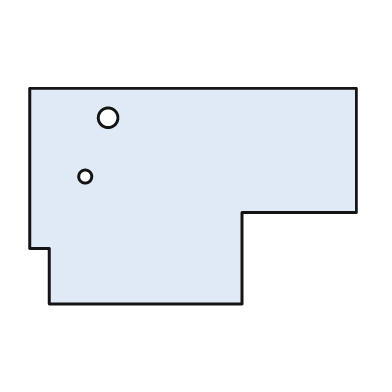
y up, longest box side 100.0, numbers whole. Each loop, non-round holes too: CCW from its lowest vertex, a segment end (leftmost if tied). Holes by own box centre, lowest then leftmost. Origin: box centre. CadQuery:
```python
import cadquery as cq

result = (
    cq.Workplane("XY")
    .moveTo(-44.0, -33.0)
    .lineTo(15.0, -33.0)
    .lineTo(15.0, -5.0)
    .lineTo(50.0, -5.0)
    .lineTo(50.0, 33.0)
    .lineTo(-50.0, 33.0)
    .lineTo(-50.0, -16.0)
    .lineTo(-44.0, -16.0)
    .close()
    .moveTo(-33.0, 6.0)
    .circle(2.0)
    .moveTo(-26.0, 24.0)
    .circle(3.0)
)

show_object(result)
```